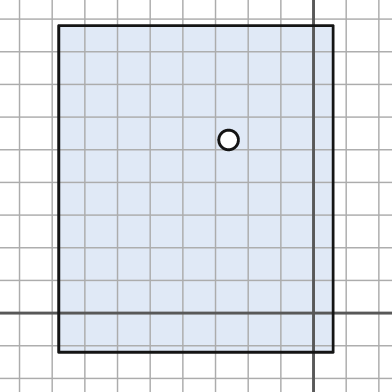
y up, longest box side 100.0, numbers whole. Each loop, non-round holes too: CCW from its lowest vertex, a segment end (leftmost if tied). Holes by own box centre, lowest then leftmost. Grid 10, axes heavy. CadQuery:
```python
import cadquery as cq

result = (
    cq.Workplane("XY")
    .moveTo(-78.0, -12.0)
    .lineTo(6.0, -12.0)
    .lineTo(6.0, 88.0)
    .lineTo(-78.0, 88.0)
    .close()
    .moveTo(-26.0, 53.0)
    .circle(3.0)
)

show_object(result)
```